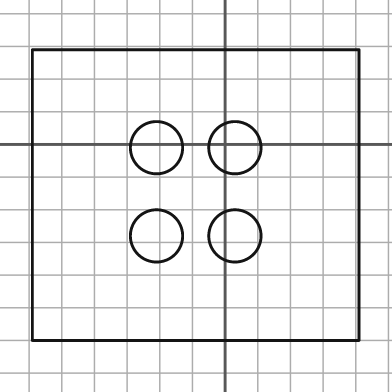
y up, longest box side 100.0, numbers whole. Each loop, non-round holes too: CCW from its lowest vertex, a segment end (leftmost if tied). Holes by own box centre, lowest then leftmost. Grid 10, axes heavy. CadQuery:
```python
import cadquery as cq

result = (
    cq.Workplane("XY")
    .moveTo(-59.0, -60.0)
    .lineTo(41.0, -60.0)
    .lineTo(41.0, 29.0)
    .lineTo(-59.0, 29.0)
    .close()
    .moveTo(-21.0, -28.0)
    .circle(8.0)
    .moveTo(3.0, -28.0)
    .circle(8.0)
    .moveTo(-21.0, -1.0)
    .circle(8.0)
    .moveTo(3.0, -1.0)
    .circle(8.0)
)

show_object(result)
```